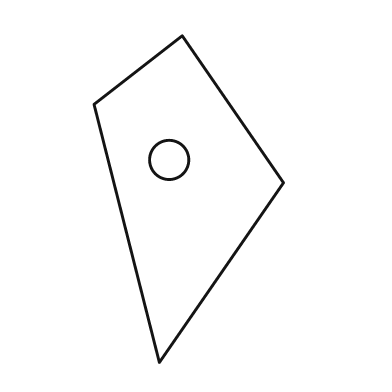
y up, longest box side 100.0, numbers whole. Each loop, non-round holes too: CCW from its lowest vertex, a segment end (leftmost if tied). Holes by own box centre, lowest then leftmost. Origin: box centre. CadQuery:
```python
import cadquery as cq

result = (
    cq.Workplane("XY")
    .moveTo(-9.0, -50.0)
    .lineTo(29.0, 5.0)
    .lineTo(-2.0, 50.0)
    .lineTo(-29.0, 29.0)
    .close()
    .moveTo(-6.0, 12.0)
    .circle(6.0)
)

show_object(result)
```